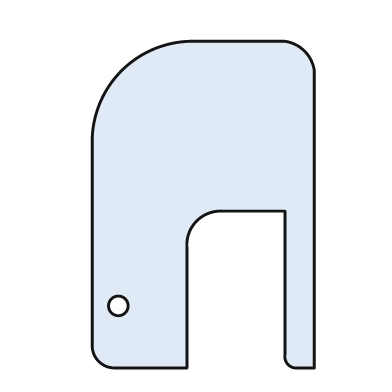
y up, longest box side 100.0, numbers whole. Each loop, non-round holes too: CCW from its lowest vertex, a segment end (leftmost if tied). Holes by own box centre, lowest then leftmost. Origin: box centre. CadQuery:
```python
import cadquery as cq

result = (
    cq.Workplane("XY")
    .moveTo(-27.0, -50.0)
    .lineTo(-5.0, -50.0)
    .lineTo(-5.0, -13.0)
    .threePointArc((-2.0, -5.0), (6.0, -2.0))
    .lineTo(25.0, -2.0)
    .lineTo(25.0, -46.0)
    .threePointArc((26.0, -49.0), (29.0, -50.0))
    .lineTo(34.0, -50.0)
    .lineTo(34.0, 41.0)
    .threePointArc((31.0, 47.0), (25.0, 50.0))
    .lineTo(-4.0, 50.0)
    .threePointArc((-25.0, 41.0), (-34.0, 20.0))
    .lineTo(-34.0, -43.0)
    .threePointArc((-32.0, -48.0), (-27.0, -50.0))
    .close()
    .moveTo(-26.0, -31.0)
    .circle(3.0)
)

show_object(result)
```